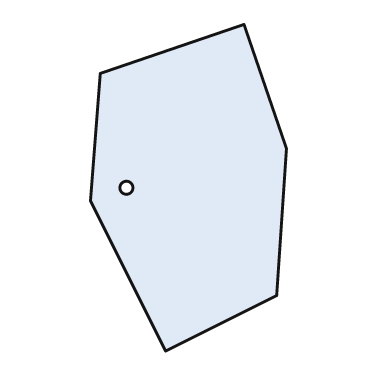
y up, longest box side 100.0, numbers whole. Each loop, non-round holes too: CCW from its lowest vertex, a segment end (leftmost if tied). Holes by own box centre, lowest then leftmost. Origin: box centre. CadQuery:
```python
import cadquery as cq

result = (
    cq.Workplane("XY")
    .moveTo(-7.0, -50.0)
    .lineTo(27.0, -33.0)
    .lineTo(30.0, 12.0)
    .lineTo(17.0, 50.0)
    .lineTo(-27.0, 35.0)
    .lineTo(-30.0, -4.0)
    .close()
    .moveTo(-19.0, 0.0)
    .circle(2.0)
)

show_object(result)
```